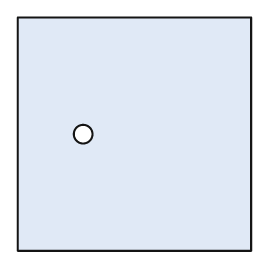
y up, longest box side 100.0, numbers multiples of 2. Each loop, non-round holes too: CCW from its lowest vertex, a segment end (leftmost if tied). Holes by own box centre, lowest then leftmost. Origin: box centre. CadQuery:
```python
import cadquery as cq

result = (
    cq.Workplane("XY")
    .moveTo(-50.0, -50.0)
    .lineTo(50.0, -50.0)
    .lineTo(50.0, 50.0)
    .lineTo(-50.0, 50.0)
    .close()
    .moveTo(-22.0, 0.0)
    .circle(4.0)
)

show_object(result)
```